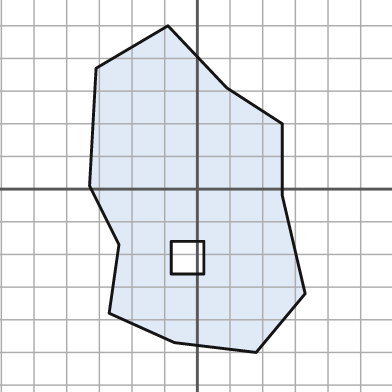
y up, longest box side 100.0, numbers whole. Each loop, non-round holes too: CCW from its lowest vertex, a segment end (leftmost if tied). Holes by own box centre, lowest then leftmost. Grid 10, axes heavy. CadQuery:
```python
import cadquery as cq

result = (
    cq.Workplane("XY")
    .moveTo(18.0, -50.0)
    .lineTo(33.0, -32.0)
    .lineTo(26.0, -2.0)
    .lineTo(26.0, 20.0)
    .lineTo(9.0, 31.0)
    .lineTo(-9.0, 50.0)
    .lineTo(-31.0, 37.0)
    .lineTo(-33.0, 1.0)
    .lineTo(-24.0, -17.0)
    .lineTo(-27.0, -38.0)
    .lineTo(-7.0, -47.0)
    .close()
    .moveTo(-8.0, -26.0)
    .lineTo(2.0, -26.0)
    .lineTo(2.0, -16.0)
    .lineTo(-8.0, -16.0)
    .close()
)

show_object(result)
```